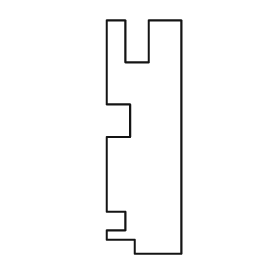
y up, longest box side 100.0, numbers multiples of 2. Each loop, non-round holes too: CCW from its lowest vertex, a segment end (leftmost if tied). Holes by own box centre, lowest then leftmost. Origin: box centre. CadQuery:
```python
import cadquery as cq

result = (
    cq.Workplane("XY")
    .moveTo(-4.0, -50.0)
    .lineTo(16.0, -50.0)
    .lineTo(16.0, 50.0)
    .lineTo(2.0, 50.0)
    .lineTo(2.0, 32.0)
    .lineTo(-8.0, 32.0)
    .lineTo(-8.0, 50.0)
    .lineTo(-16.0, 50.0)
    .lineTo(-16.0, 14.0)
    .lineTo(-6.0, 14.0)
    .lineTo(-6.0, 0.0)
    .lineTo(-16.0, 0.0)
    .lineTo(-16.0, -32.0)
    .lineTo(-8.0, -32.0)
    .lineTo(-8.0, -40.0)
    .lineTo(-16.0, -40.0)
    .lineTo(-16.0, -44.0)
    .lineTo(-4.0, -44.0)
    .close()
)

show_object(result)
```